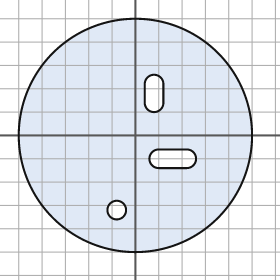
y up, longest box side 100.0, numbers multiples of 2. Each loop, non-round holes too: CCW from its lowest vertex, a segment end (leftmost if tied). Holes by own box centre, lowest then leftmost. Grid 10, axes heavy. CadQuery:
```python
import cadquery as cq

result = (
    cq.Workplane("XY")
    .moveTo(0.0, 0.0)
    .circle(50.0)
    .moveTo(-8.0, -32.0)
    .circle(4.0)
    .moveTo(10.0, -14.0)
    .lineTo(22.0, -14.0)
    .threePointArc((26.0, -10.0), (22.0, -6.0))
    .lineTo(10.0, -6.0)
    .threePointArc((6.0, -10.0), (10.0, -14.0))
    .close()
    .moveTo(4.0, 14.0)
    .threePointArc((8.0, 10.0), (12.0, 14.0))
    .lineTo(12.0, 22.0)
    .threePointArc((8.0, 26.0), (4.0, 22.0))
    .close()
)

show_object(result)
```